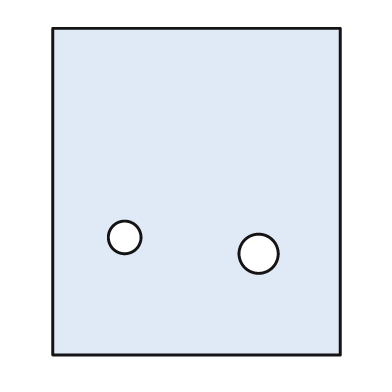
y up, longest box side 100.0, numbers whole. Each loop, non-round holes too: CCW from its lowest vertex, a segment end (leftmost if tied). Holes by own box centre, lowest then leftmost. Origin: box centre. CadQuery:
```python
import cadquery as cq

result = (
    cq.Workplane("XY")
    .moveTo(-44.0, -50.0)
    .lineTo(44.0, -50.0)
    .lineTo(44.0, 50.0)
    .lineTo(-44.0, 50.0)
    .close()
    .moveTo(19.0, -19.0)
    .circle(6.0)
    .moveTo(-22.0, -14.0)
    .circle(5.0)
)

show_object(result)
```